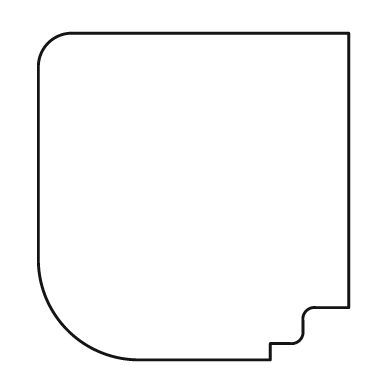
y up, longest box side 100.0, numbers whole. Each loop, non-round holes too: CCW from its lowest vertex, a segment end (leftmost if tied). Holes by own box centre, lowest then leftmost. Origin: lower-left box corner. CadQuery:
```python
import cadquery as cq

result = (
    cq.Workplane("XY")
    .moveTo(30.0, 0.0)
    .lineTo(71.0, 0.0)
    .lineTo(71.0, 5.0)
    .lineTo(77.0, 5.0)
    .threePointArc((80.0, 6.0), (81.0, 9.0))
    .lineTo(81.0, 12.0)
    .threePointArc((82.0, 15.0), (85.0, 16.0))
    .lineTo(95.0, 16.0)
    .lineTo(95.0, 100.0)
    .lineTo(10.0, 100.0)
    .threePointArc((3.0, 97.0), (0.0, 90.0))
    .lineTo(0.0, 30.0)
    .threePointArc((9.0, 9.0), (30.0, 0.0))
    .close()
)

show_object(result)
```